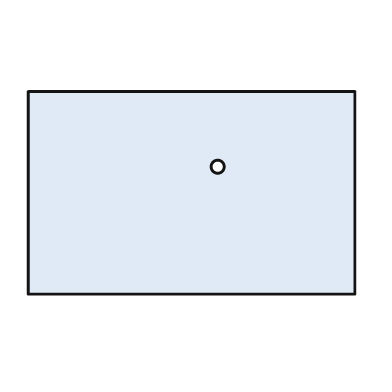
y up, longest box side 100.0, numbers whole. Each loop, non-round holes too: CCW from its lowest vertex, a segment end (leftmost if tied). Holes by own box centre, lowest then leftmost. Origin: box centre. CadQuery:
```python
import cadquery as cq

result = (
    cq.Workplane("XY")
    .moveTo(-50.0, -31.0)
    .lineTo(50.0, -31.0)
    .lineTo(50.0, 31.0)
    .lineTo(-50.0, 31.0)
    .close()
    .moveTo(8.0, 8.0)
    .circle(2.0)
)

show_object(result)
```